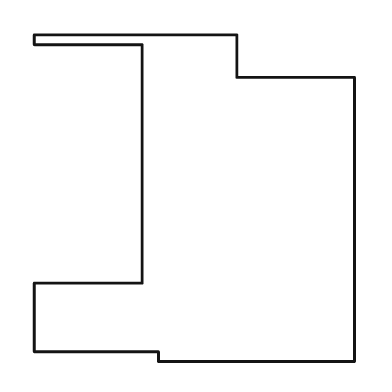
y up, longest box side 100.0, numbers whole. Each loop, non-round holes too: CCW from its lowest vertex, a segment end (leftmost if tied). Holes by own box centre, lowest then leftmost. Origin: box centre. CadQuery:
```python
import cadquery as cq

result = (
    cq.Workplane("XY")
    .moveTo(-11.0, -50.0)
    .lineTo(49.0, -50.0)
    .lineTo(49.0, 37.0)
    .lineTo(13.0, 37.0)
    .lineTo(13.0, 50.0)
    .lineTo(-49.0, 50.0)
    .lineTo(-49.0, 47.0)
    .lineTo(-16.0, 47.0)
    .lineTo(-16.0, -26.0)
    .lineTo(-49.0, -26.0)
    .lineTo(-49.0, -47.0)
    .lineTo(-11.0, -47.0)
    .close()
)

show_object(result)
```